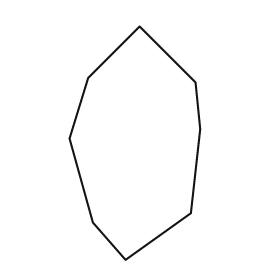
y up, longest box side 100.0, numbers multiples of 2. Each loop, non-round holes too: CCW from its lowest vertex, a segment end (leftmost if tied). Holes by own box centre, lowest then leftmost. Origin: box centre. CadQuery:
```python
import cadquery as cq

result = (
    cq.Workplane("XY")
    .moveTo(-4.0, -50.0)
    .lineTo(24.0, -30.0)
    .lineTo(28.0, 6.0)
    .lineTo(26.0, 26.0)
    .lineTo(2.0, 50.0)
    .lineTo(-20.0, 28.0)
    .lineTo(-28.0, 2.0)
    .lineTo(-18.0, -34.0)
    .close()
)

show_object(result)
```